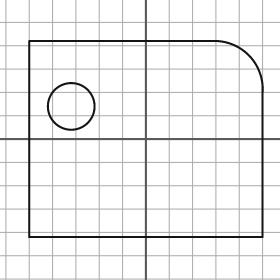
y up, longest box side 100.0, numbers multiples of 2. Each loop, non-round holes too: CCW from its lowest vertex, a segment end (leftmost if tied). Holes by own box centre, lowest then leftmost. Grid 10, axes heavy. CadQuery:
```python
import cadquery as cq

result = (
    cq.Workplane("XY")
    .moveTo(-50.0, -42.0)
    .lineTo(50.0, -42.0)
    .lineTo(50.0, 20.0)
    .threePointArc((44.0, 36.0), (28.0, 42.0))
    .lineTo(-50.0, 42.0)
    .close()
    .moveTo(-32.0, 14.0)
    .circle(10.0)
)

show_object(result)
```